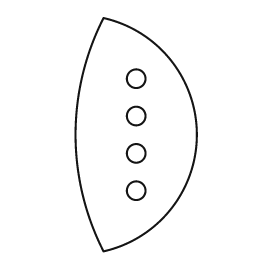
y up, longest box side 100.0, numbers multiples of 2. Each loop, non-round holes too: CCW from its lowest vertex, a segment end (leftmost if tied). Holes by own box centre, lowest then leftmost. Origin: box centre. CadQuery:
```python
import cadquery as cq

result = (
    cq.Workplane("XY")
    .moveTo(-14.0, -50.0)
    .threePointArc((26.0, 0.0), (-14.0, 50.0))
    .threePointArc((-26.0, 0.0), (-14.0, -50.0))
    .close()
    .moveTo(0.0, -24.0)
    .circle(4.0)
    .moveTo(0.0, -8.0)
    .circle(4.0)
    .moveTo(0.0, 8.0)
    .circle(4.0)
    .moveTo(0.0, 24.0)
    .circle(4.0)
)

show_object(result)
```